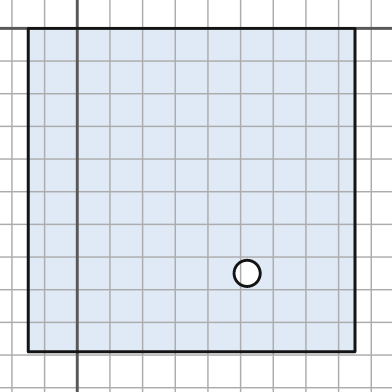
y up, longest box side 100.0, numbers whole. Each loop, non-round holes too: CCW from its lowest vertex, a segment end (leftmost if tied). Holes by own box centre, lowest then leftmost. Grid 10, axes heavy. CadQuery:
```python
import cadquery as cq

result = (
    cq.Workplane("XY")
    .moveTo(-15.0, -99.0)
    .lineTo(85.0, -99.0)
    .lineTo(85.0, 0.0)
    .lineTo(-15.0, 0.0)
    .close()
    .moveTo(52.0, -75.0)
    .circle(4.0)
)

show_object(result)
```